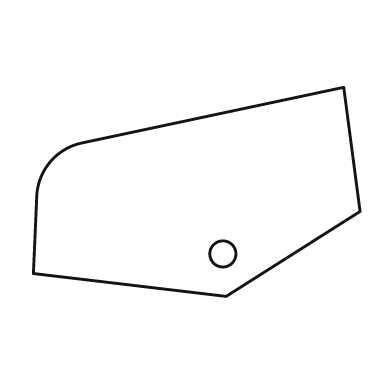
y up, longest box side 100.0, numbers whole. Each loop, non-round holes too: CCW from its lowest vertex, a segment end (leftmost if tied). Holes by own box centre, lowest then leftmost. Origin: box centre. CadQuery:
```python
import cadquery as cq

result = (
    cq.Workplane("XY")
    .moveTo(9.0, -32.0)
    .lineTo(50.0, -6.0)
    .lineTo(45.0, 32.0)
    .lineTo(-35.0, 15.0)
    .threePointArc((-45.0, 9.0), (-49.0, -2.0))
    .lineTo(-50.0, -25.0)
    .close()
    .moveTo(8.0, -19.0)
    .circle(4.0)
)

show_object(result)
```